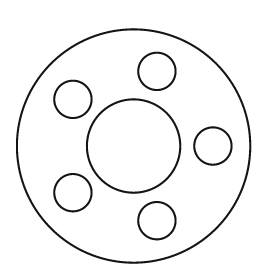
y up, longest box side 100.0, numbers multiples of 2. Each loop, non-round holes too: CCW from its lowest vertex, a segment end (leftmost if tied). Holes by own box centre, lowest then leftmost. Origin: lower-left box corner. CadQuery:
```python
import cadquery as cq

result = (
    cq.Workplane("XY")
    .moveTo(50.0, 50.0)
    .circle(50.0)
    .moveTo(60.0, 18.0)
    .circle(8.0)
    .moveTo(24.0, 30.0)
    .circle(8.0)
    .moveTo(50.0, 50.0)
    .circle(20.0)
    .moveTo(84.0, 50.0)
    .circle(8.0)
    .moveTo(24.0, 70.0)
    .circle(8.0)
    .moveTo(60.0, 82.0)
    .circle(8.0)
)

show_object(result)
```